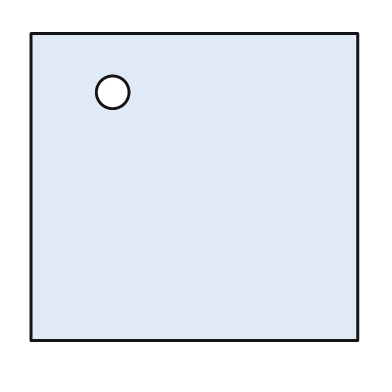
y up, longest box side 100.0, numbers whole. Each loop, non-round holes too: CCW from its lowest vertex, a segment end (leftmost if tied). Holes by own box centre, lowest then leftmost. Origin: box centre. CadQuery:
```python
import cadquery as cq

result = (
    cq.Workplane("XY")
    .moveTo(-50.0, -47.0)
    .lineTo(50.0, -47.0)
    .lineTo(50.0, 47.0)
    .lineTo(-50.0, 47.0)
    .close()
    .moveTo(-25.0, 29.0)
    .circle(5.0)
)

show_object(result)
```